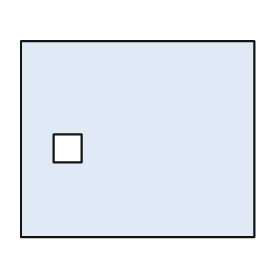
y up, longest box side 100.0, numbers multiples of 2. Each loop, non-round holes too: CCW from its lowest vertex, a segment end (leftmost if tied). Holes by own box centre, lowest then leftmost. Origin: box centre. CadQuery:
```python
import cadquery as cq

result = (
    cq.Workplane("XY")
    .moveTo(-50.0, -42.0)
    .lineTo(50.0, -42.0)
    .lineTo(50.0, 42.0)
    .lineTo(-50.0, 42.0)
    .close()
    .moveTo(-36.0, -10.0)
    .lineTo(-24.0, -10.0)
    .lineTo(-24.0, 2.0)
    .lineTo(-36.0, 2.0)
    .close()
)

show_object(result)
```